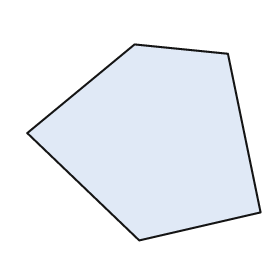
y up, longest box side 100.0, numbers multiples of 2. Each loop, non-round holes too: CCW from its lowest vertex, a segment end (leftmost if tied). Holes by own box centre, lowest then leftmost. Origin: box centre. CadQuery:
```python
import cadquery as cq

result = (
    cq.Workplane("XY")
    .moveTo(-2.0, -42.0)
    .lineTo(50.0, -30.0)
    .lineTo(36.0, 38.0)
    .lineTo(-4.0, 42.0)
    .lineTo(-50.0, 4.0)
    .close()
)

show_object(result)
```